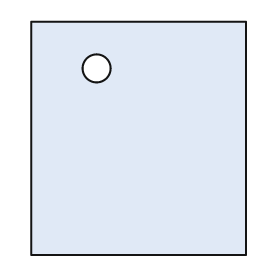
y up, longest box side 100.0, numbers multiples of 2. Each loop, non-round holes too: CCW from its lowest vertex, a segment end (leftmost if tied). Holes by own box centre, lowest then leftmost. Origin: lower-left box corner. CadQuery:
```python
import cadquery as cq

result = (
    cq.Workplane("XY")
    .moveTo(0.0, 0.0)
    .lineTo(92.0, 0.0)
    .lineTo(92.0, 100.0)
    .lineTo(0.0, 100.0)
    .close()
    .moveTo(28.0, 80.0)
    .circle(6.0)
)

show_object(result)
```